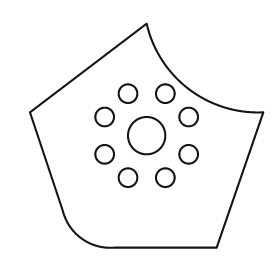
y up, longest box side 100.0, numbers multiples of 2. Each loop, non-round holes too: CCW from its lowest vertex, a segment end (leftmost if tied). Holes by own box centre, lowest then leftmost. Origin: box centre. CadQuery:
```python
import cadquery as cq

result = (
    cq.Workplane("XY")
    .moveTo(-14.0, -48.0)
    .lineTo(30.0, -48.0)
    .lineTo(50.0, 10.0)
    .threePointArc((18.0, 20.0), (0.0, 48.0))
    .lineTo(-50.0, 10.0)
    .lineTo(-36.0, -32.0)
    .threePointArc((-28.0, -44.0), (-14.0, -48.0))
    .close()
    .moveTo(-8.0, -18.0)
    .circle(4.0)
    .moveTo(8.0, -18.0)
    .circle(4.0)
    .moveTo(-18.0, -8.0)
    .circle(4.0)
    .moveTo(18.0, -8.0)
    .circle(4.0)
    .moveTo(0.0, 0.0)
    .circle(8.0)
    .moveTo(-18.0, 8.0)
    .circle(4.0)
    .moveTo(18.0, 8.0)
    .circle(4.0)
    .moveTo(-8.0, 18.0)
    .circle(4.0)
    .moveTo(8.0, 18.0)
    .circle(4.0)
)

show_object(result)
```